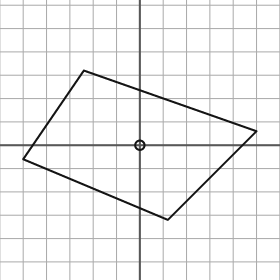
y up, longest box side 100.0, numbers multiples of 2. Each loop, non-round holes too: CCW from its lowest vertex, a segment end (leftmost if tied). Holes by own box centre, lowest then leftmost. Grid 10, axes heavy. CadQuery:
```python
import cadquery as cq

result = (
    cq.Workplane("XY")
    .moveTo(12.0, -32.0)
    .lineTo(50.0, 6.0)
    .lineTo(-24.0, 32.0)
    .lineTo(-50.0, -6.0)
    .close()
    .moveTo(0.0, 0.0)
    .circle(2.0)
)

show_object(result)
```